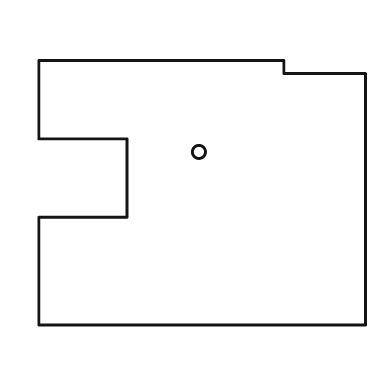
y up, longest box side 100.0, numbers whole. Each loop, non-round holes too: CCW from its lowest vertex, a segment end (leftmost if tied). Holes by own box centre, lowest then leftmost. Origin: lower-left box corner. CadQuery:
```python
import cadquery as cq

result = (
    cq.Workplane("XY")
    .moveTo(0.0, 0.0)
    .lineTo(100.0, 0.0)
    .lineTo(100.0, 77.0)
    .lineTo(75.0, 77.0)
    .lineTo(75.0, 81.0)
    .lineTo(0.0, 81.0)
    .lineTo(0.0, 57.0)
    .lineTo(27.0, 57.0)
    .lineTo(27.0, 33.0)
    .lineTo(0.0, 33.0)
    .close()
    .moveTo(49.0, 53.0)
    .circle(2.0)
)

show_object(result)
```